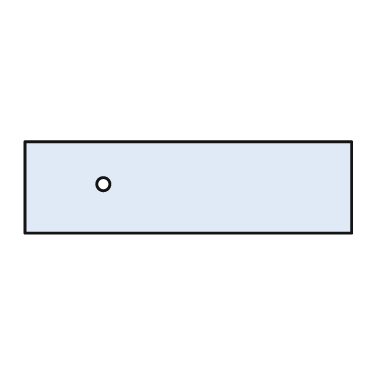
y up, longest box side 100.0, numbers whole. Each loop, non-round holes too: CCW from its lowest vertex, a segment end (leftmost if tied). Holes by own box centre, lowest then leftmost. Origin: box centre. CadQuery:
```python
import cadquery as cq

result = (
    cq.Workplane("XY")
    .moveTo(-50.0, -14.0)
    .lineTo(50.0, -14.0)
    .lineTo(50.0, 14.0)
    .lineTo(-50.0, 14.0)
    .close()
    .moveTo(-26.0, 1.0)
    .circle(2.0)
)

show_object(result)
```